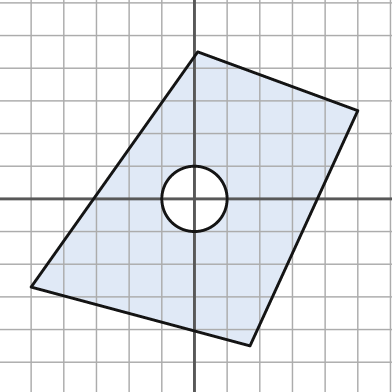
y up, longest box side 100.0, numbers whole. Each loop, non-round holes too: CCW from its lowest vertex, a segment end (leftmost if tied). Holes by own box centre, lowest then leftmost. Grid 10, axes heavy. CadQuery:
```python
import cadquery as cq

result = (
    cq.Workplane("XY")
    .moveTo(17.0, -45.0)
    .lineTo(50.0, 27.0)
    .lineTo(1.0, 45.0)
    .lineTo(-50.0, -27.0)
    .close()
    .moveTo(0.0, 0.0)
    .circle(10.0)
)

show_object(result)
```